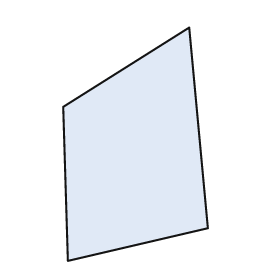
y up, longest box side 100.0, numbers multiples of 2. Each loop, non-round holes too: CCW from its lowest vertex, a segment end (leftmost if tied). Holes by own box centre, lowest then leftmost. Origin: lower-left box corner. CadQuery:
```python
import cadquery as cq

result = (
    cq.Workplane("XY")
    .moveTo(2.0, 0.0)
    .lineTo(62.0, 14.0)
    .lineTo(54.0, 100.0)
    .lineTo(0.0, 66.0)
    .close()
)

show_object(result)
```